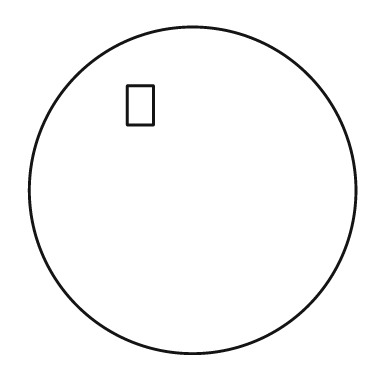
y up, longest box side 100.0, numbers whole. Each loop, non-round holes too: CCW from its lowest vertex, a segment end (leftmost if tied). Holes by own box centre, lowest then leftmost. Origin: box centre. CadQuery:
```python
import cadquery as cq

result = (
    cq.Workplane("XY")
    .moveTo(0.0, 0.0)
    .circle(50.0)
    .moveTo(-20.0, 20.0)
    .lineTo(-12.0, 20.0)
    .lineTo(-12.0, 32.0)
    .lineTo(-20.0, 32.0)
    .close()
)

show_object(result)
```